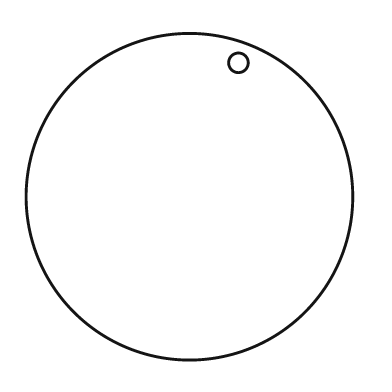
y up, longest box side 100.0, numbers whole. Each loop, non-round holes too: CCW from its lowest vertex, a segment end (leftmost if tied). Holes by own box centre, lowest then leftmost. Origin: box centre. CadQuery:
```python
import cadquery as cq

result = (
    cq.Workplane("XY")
    .moveTo(0.0, 0.0)
    .circle(50.0)
    .moveTo(15.0, 41.0)
    .circle(3.0)
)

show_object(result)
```